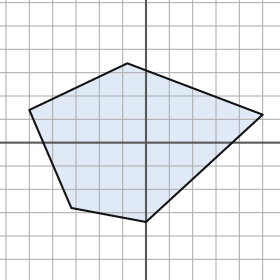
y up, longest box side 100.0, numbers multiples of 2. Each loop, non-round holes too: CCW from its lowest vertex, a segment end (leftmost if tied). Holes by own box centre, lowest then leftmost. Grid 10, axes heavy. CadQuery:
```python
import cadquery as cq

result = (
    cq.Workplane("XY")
    .moveTo(0.0, -34.0)
    .lineTo(50.0, 12.0)
    .lineTo(-8.0, 34.0)
    .lineTo(-50.0, 14.0)
    .lineTo(-32.0, -28.0)
    .close()
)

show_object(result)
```